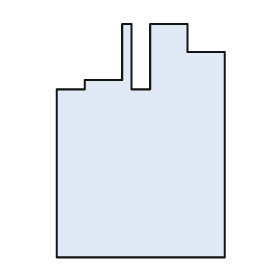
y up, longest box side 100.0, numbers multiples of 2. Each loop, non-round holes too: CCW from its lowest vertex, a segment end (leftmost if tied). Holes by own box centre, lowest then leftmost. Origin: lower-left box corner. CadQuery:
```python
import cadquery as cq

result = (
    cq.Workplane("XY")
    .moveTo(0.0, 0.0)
    .lineTo(72.0, 0.0)
    .lineTo(72.0, 88.0)
    .lineTo(56.0, 88.0)
    .lineTo(56.0, 100.0)
    .lineTo(40.0, 100.0)
    .lineTo(40.0, 72.0)
    .lineTo(32.0, 72.0)
    .lineTo(32.0, 100.0)
    .lineTo(28.0, 100.0)
    .lineTo(28.0, 76.0)
    .lineTo(12.0, 76.0)
    .lineTo(12.0, 72.0)
    .lineTo(0.0, 72.0)
    .close()
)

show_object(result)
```